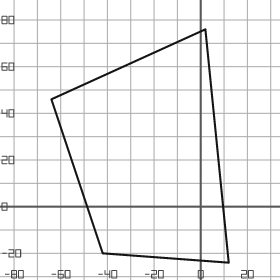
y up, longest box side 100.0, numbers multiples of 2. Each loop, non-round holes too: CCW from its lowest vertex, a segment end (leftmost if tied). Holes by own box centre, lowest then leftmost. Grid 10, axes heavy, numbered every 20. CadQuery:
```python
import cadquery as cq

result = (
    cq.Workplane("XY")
    .moveTo(12.0, -24.0)
    .lineTo(2.0, 76.0)
    .lineTo(-64.0, 46.0)
    .lineTo(-42.0, -20.0)
    .close()
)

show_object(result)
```